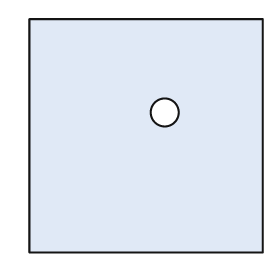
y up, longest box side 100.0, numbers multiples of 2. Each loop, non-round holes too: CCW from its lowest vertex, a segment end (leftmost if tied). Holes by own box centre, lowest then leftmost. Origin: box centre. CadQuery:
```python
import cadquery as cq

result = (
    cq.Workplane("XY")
    .moveTo(-50.0, -50.0)
    .lineTo(50.0, -50.0)
    .lineTo(50.0, 50.0)
    .lineTo(-50.0, 50.0)
    .close()
    .moveTo(8.0, 10.0)
    .circle(6.0)
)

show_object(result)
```